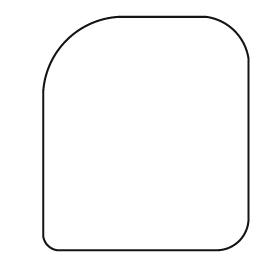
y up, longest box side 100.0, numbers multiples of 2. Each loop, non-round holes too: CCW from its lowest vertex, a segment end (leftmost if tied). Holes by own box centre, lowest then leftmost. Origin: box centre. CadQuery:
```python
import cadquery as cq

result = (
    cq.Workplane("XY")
    .moveTo(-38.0, -50.0)
    .lineTo(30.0, -50.0)
    .threePointArc((40.0, -46.0), (44.0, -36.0))
    .lineTo(44.0, 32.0)
    .threePointArc((38.0, 44.0), (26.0, 50.0))
    .lineTo(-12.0, 50.0)
    .threePointArc((-34.0, 40.0), (-44.0, 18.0))
    .lineTo(-44.0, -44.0)
    .threePointArc((-42.0, -48.0), (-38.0, -50.0))
    .close()
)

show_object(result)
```